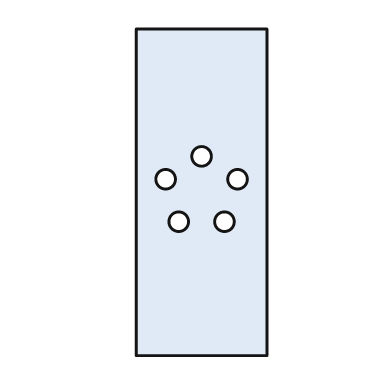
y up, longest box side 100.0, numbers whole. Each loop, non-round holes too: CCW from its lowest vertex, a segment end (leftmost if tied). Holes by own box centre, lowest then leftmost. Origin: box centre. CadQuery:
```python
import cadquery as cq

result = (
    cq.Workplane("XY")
    .moveTo(-20.0, -50.0)
    .lineTo(20.0, -50.0)
    .lineTo(20.0, 50.0)
    .lineTo(-20.0, 50.0)
    .close()
    .moveTo(-7.0, -9.0)
    .circle(3.0)
    .moveTo(7.0, -9.0)
    .circle(3.0)
    .moveTo(-11.0, 4.0)
    .circle(3.0)
    .moveTo(11.0, 4.0)
    .circle(3.0)
    .moveTo(0.0, 11.0)
    .circle(3.0)
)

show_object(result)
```